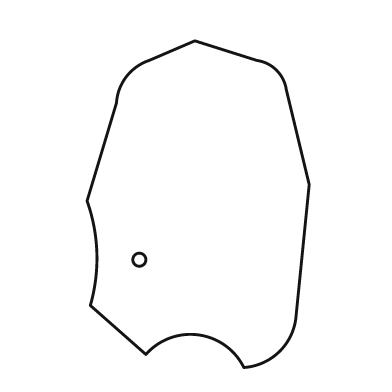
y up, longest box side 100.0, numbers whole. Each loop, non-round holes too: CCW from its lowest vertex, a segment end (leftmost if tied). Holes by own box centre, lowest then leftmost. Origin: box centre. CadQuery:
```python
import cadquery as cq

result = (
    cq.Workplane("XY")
    .moveTo(14.0, -50.0)
    .threePointArc((25.0, -45.0), (30.0, -34.0))
    .lineTo(34.0, 6.0)
    .lineTo(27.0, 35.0)
    .threePointArc((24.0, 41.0), (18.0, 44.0))
    .lineTo(-1.0, 50.0)
    .lineTo(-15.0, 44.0)
    .threePointArc((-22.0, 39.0), (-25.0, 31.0))
    .lineTo(-34.0, 1.0)
    .threePointArc((-31.0, -15.0), (-33.0, -31.0))
    .lineTo(-16.0, -46.0)
    .threePointArc((0.0, -40.0), (14.0, -50.0))
    .close()
    .moveTo(-18.0, -17.0)
    .circle(2.0)
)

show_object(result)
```